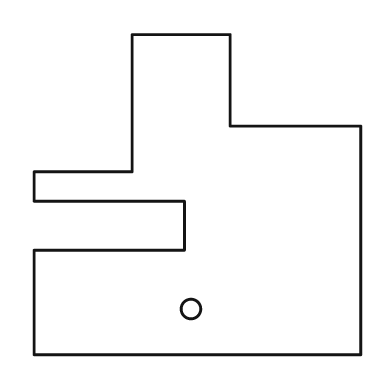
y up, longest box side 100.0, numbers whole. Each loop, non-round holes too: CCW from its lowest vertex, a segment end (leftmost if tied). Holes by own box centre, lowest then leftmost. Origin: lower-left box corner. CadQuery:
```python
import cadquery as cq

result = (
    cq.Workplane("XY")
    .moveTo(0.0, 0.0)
    .lineTo(100.0, 0.0)
    .lineTo(100.0, 70.0)
    .lineTo(60.0, 70.0)
    .lineTo(60.0, 98.0)
    .lineTo(30.0, 98.0)
    .lineTo(30.0, 56.0)
    .lineTo(0.0, 56.0)
    .lineTo(0.0, 47.0)
    .lineTo(46.0, 47.0)
    .lineTo(46.0, 32.0)
    .lineTo(0.0, 32.0)
    .close()
    .moveTo(48.0, 14.0)
    .circle(3.0)
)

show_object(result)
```